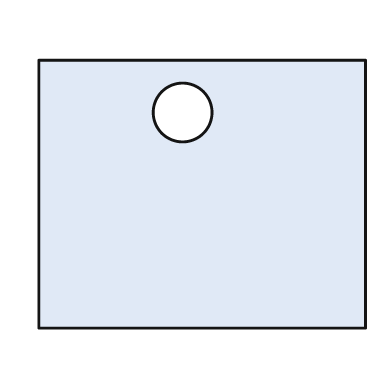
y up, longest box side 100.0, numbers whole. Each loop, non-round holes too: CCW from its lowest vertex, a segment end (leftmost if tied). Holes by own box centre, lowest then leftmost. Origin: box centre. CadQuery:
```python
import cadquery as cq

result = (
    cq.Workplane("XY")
    .moveTo(-50.0, -41.0)
    .lineTo(50.0, -41.0)
    .lineTo(50.0, 41.0)
    .lineTo(-50.0, 41.0)
    .close()
    .moveTo(-6.0, 25.0)
    .circle(9.0)
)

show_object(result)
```